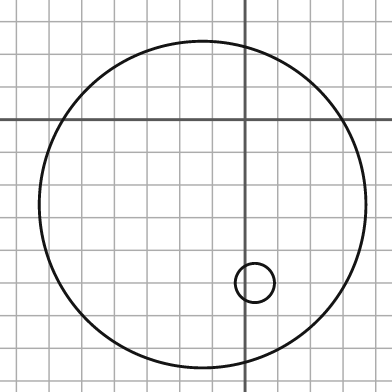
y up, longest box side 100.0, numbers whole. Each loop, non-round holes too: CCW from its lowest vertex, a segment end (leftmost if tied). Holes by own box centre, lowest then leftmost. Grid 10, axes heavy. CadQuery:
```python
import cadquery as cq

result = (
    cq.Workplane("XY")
    .moveTo(-13.0, -26.0)
    .circle(50.0)
    .moveTo(3.0, -50.0)
    .circle(6.0)
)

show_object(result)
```